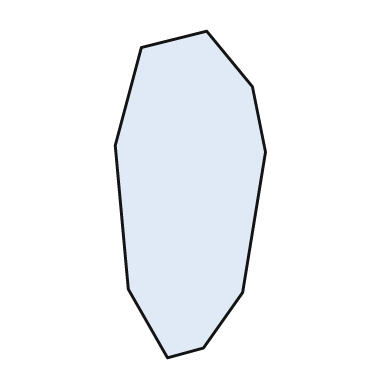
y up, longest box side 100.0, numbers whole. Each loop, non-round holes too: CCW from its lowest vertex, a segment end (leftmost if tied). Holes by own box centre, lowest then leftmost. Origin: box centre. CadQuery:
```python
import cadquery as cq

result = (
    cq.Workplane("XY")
    .moveTo(-7.0, -50.0)
    .lineTo(4.0, -47.0)
    .lineTo(16.0, -30.0)
    .lineTo(23.0, 13.0)
    .lineTo(19.0, 33.0)
    .lineTo(5.0, 50.0)
    .lineTo(-15.0, 45.0)
    .lineTo(-23.0, 15.0)
    .lineTo(-19.0, -29.0)
    .close()
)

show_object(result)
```